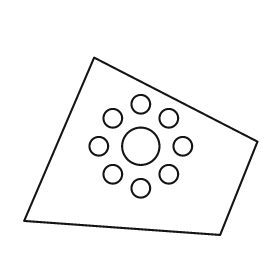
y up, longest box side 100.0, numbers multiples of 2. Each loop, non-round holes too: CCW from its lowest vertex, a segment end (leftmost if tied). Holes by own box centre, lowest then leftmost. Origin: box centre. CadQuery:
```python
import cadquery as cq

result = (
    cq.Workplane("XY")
    .moveTo(34.0, -38.0)
    .lineTo(50.0, 2.0)
    .lineTo(-20.0, 38.0)
    .lineTo(-50.0, -32.0)
    .close()
    .moveTo(0.0, -18.0)
    .circle(4.0)
    .moveTo(-12.0, -12.0)
    .circle(4.0)
    .moveTo(12.0, -12.0)
    .circle(4.0)
    .moveTo(-18.0, 0.0)
    .circle(4.0)
    .moveTo(0.0, 0.0)
    .circle(8.0)
    .moveTo(18.0, 0.0)
    .circle(4.0)
    .moveTo(-12.0, 12.0)
    .circle(4.0)
    .moveTo(12.0, 12.0)
    .circle(4.0)
    .moveTo(0.0, 18.0)
    .circle(4.0)
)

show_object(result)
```